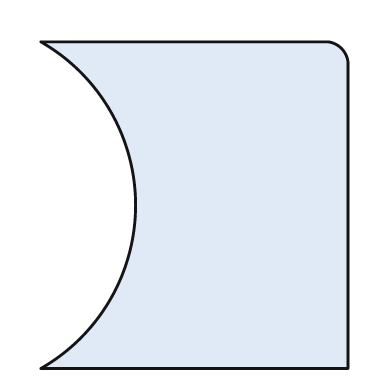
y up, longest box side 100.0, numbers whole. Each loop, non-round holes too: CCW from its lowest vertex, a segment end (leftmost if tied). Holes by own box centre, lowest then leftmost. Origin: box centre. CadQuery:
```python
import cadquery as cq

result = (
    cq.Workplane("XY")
    .moveTo(-47.0, -50.0)
    .lineTo(47.0, -50.0)
    .lineTo(47.0, 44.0)
    .threePointArc((45.0, 48.0), (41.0, 50.0))
    .lineTo(-47.0, 50.0)
    .threePointArc((-18.0, 0.0), (-47.0, -50.0))
    .close()
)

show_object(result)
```